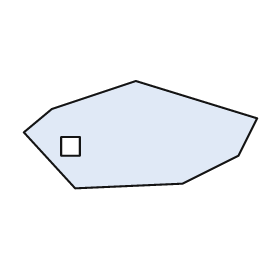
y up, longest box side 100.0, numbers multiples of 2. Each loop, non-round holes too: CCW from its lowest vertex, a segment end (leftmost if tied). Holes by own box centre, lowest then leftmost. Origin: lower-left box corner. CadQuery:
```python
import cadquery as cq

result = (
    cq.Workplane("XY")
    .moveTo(22.0, 0.0)
    .lineTo(68.0, 2.0)
    .lineTo(92.0, 14.0)
    .lineTo(100.0, 30.0)
    .lineTo(48.0, 46.0)
    .lineTo(12.0, 34.0)
    .lineTo(0.0, 24.0)
    .close()
    .moveTo(16.0, 14.0)
    .lineTo(24.0, 14.0)
    .lineTo(24.0, 22.0)
    .lineTo(16.0, 22.0)
    .close()
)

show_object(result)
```